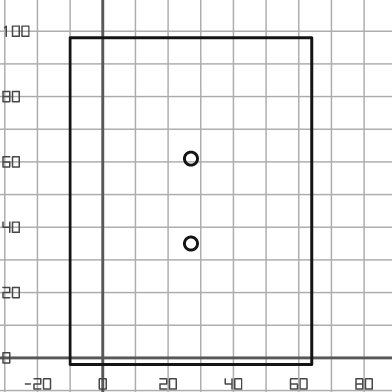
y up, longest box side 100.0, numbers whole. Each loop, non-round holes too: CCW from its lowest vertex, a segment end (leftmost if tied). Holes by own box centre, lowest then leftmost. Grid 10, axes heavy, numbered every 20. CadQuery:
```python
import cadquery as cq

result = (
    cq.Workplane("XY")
    .moveTo(-10.0, -2.0)
    .lineTo(64.0, -2.0)
    .lineTo(64.0, 98.0)
    .lineTo(-10.0, 98.0)
    .close()
    .moveTo(27.0, 35.0)
    .circle(2.0)
    .moveTo(27.0, 61.0)
    .circle(2.0)
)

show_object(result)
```